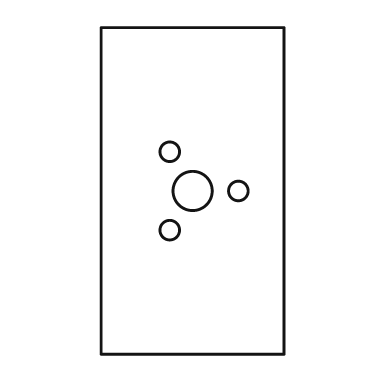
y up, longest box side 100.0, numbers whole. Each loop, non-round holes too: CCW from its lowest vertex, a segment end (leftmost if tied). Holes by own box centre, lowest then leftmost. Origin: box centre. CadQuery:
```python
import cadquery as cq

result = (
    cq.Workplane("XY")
    .moveTo(-28.0, -50.0)
    .lineTo(28.0, -50.0)
    .lineTo(28.0, 50.0)
    .lineTo(-28.0, 50.0)
    .close()
    .moveTo(-7.0, -12.0)
    .circle(3.0)
    .moveTo(0.0, 0.0)
    .circle(6.0)
    .moveTo(14.0, 0.0)
    .circle(3.0)
    .moveTo(-7.0, 12.0)
    .circle(3.0)
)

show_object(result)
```